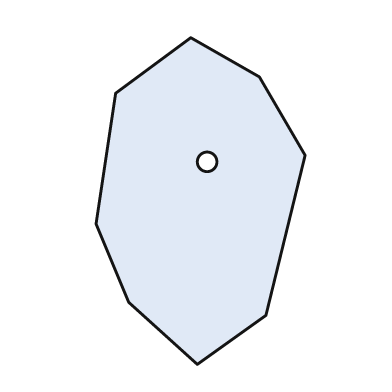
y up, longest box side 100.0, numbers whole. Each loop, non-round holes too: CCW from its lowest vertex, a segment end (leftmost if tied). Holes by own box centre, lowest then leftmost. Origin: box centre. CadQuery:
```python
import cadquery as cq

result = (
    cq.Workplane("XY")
    .moveTo(-1.0, -50.0)
    .lineTo(20.0, -35.0)
    .lineTo(32.0, 14.0)
    .lineTo(18.0, 38.0)
    .lineTo(-3.0, 50.0)
    .lineTo(-26.0, 33.0)
    .lineTo(-32.0, -7.0)
    .lineTo(-22.0, -31.0)
    .close()
    .moveTo(2.0, 12.0)
    .circle(3.0)
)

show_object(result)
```